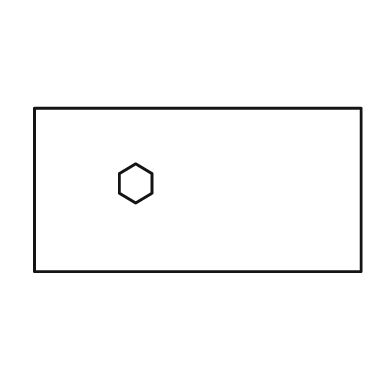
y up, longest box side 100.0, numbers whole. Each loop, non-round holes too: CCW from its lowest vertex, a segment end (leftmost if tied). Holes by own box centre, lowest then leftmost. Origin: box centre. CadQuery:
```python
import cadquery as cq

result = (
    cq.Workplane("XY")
    .moveTo(-50.0, -25.0)
    .lineTo(50.0, -25.0)
    .lineTo(50.0, 25.0)
    .lineTo(-50.0, 25.0)
    .close()
    .moveTo(-19.0, -4.0)
    .lineTo(-14.0, -1.0)
    .lineTo(-14.0, 5.0)
    .lineTo(-19.0, 8.0)
    .lineTo(-24.0, 5.0)
    .lineTo(-24.0, -1.0)
    .close()
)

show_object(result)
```